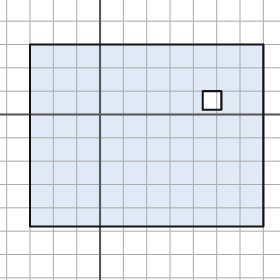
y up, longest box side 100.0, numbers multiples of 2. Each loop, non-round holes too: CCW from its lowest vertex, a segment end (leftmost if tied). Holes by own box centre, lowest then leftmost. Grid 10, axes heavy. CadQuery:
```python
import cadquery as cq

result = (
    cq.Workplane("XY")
    .moveTo(-30.0, -48.0)
    .lineTo(70.0, -48.0)
    .lineTo(70.0, 30.0)
    .lineTo(-30.0, 30.0)
    .close()
    .moveTo(44.0, 2.0)
    .lineTo(52.0, 2.0)
    .lineTo(52.0, 10.0)
    .lineTo(44.0, 10.0)
    .close()
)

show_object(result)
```